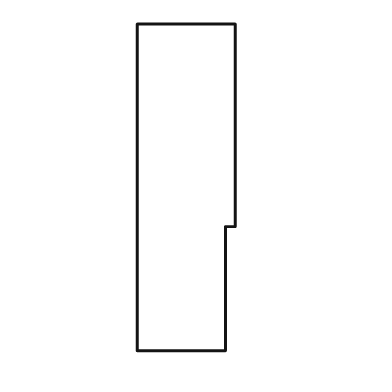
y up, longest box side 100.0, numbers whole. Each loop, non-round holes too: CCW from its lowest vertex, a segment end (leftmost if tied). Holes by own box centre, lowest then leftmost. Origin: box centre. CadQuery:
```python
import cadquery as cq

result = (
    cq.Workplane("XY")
    .moveTo(-15.0, -50.0)
    .lineTo(12.0, -50.0)
    .lineTo(12.0, -12.0)
    .lineTo(15.0, -12.0)
    .lineTo(15.0, 50.0)
    .lineTo(-15.0, 50.0)
    .close()
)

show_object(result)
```